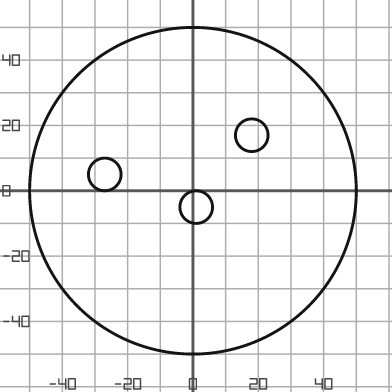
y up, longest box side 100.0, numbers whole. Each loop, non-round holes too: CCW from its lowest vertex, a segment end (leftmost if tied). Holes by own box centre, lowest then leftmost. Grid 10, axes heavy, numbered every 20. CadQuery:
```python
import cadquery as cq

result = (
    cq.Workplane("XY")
    .moveTo(0.0, 0.0)
    .circle(50.0)
    .moveTo(1.0, -5.0)
    .circle(5.0)
    .moveTo(-27.0, 5.0)
    .circle(5.0)
    .moveTo(18.0, 17.0)
    .circle(5.0)
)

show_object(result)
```